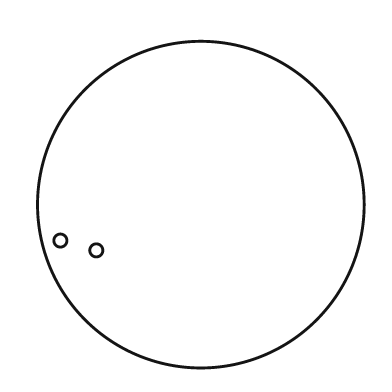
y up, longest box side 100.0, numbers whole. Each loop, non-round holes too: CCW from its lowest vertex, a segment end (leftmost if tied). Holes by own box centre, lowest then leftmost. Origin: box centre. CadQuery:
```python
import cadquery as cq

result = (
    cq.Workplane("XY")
    .moveTo(0.0, 0.0)
    .circle(50.0)
    .moveTo(-32.0, -14.0)
    .circle(2.0)
    .moveTo(-43.0, -11.0)
    .circle(2.0)
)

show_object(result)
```